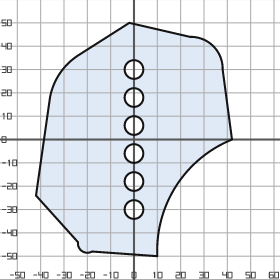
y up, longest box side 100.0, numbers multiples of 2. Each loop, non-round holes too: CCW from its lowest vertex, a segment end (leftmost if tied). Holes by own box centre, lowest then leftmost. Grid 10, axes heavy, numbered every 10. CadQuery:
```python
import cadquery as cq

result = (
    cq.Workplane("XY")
    .moveTo(10.0, -50.0)
    .threePointArc((18.0, -20.0), (42.0, 0.0))
    .lineTo(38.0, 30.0)
    .threePointArc((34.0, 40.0), (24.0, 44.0))
    .lineTo(-2.0, 50.0)
    .lineTo(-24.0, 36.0)
    .threePointArc((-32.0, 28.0), (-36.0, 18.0))
    .lineTo(-42.0, -24.0)
    .lineTo(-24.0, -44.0)
    .threePointArc((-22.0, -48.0), (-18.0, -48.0))
    .close()
    .moveTo(0.0, -30.0)
    .circle(4.0)
    .moveTo(0.0, -18.0)
    .circle(4.0)
    .moveTo(0.0, -6.0)
    .circle(4.0)
    .moveTo(0.0, 6.0)
    .circle(4.0)
    .moveTo(0.0, 18.0)
    .circle(4.0)
    .moveTo(0.0, 30.0)
    .circle(4.0)
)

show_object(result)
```